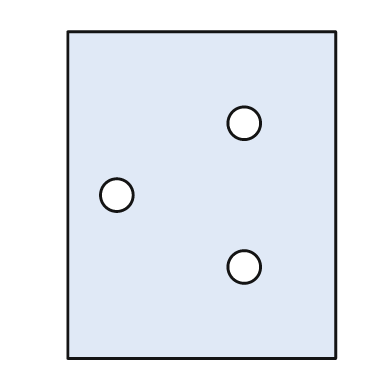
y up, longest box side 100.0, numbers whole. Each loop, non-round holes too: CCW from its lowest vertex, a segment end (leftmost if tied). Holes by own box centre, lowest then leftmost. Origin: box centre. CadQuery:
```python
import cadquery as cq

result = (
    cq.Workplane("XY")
    .moveTo(-41.0, -50.0)
    .lineTo(41.0, -50.0)
    .lineTo(41.0, 50.0)
    .lineTo(-41.0, 50.0)
    .close()
    .moveTo(13.0, -22.0)
    .circle(5.0)
    .moveTo(-26.0, 0.0)
    .circle(5.0)
    .moveTo(13.0, 22.0)
    .circle(5.0)
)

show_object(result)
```